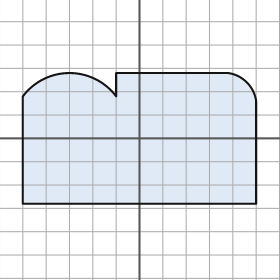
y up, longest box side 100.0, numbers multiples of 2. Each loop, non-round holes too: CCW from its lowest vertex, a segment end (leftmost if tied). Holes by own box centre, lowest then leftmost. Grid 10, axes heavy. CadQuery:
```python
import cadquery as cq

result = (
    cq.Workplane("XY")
    .moveTo(-50.0, -28.0)
    .lineTo(50.0, -28.0)
    .lineTo(50.0, 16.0)
    .threePointArc((46.0, 24.0), (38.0, 28.0))
    .lineTo(-10.0, 28.0)
    .lineTo(-10.0, 18.0)
    .threePointArc((-30.0, 28.0), (-50.0, 18.0))
    .close()
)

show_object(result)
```